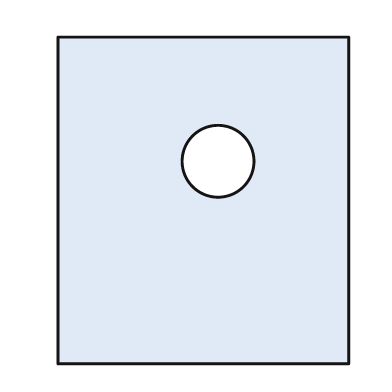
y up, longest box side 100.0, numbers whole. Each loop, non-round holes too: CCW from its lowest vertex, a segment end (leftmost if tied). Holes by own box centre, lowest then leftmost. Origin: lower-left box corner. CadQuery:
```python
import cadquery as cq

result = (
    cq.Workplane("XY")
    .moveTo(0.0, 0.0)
    .lineTo(89.0, 0.0)
    .lineTo(89.0, 100.0)
    .lineTo(0.0, 100.0)
    .close()
    .moveTo(49.0, 62.0)
    .circle(11.0)
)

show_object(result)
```